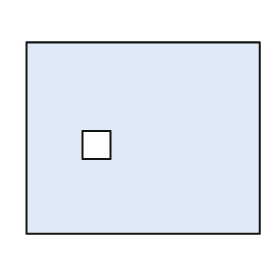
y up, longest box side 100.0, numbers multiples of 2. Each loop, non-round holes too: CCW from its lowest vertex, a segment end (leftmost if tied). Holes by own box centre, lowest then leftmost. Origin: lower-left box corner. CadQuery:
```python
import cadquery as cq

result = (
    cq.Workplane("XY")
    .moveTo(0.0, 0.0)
    .lineTo(100.0, 0.0)
    .lineTo(100.0, 82.0)
    .lineTo(0.0, 82.0)
    .close()
    .moveTo(24.0, 32.0)
    .lineTo(36.0, 32.0)
    .lineTo(36.0, 44.0)
    .lineTo(24.0, 44.0)
    .close()
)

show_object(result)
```